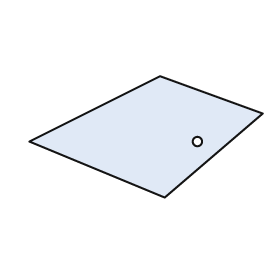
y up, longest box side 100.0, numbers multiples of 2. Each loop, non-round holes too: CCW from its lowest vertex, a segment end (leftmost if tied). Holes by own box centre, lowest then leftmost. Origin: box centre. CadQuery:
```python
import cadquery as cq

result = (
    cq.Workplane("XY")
    .moveTo(8.0, -26.0)
    .lineTo(50.0, 10.0)
    .lineTo(6.0, 26.0)
    .lineTo(-50.0, -2.0)
    .close()
    .moveTo(22.0, -2.0)
    .circle(2.0)
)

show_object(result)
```